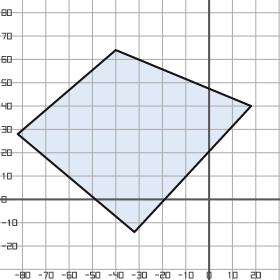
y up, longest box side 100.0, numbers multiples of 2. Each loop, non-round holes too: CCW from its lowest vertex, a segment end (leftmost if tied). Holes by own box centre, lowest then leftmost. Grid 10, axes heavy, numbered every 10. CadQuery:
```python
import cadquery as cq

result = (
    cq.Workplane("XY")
    .moveTo(-32.0, -14.0)
    .lineTo(18.0, 40.0)
    .lineTo(-40.0, 64.0)
    .lineTo(-82.0, 28.0)
    .close()
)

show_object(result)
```